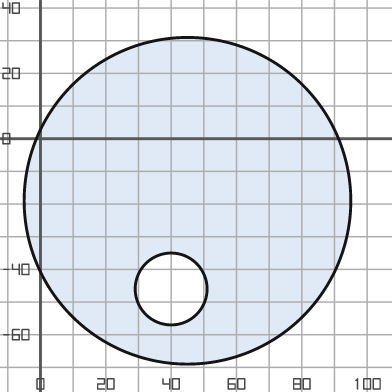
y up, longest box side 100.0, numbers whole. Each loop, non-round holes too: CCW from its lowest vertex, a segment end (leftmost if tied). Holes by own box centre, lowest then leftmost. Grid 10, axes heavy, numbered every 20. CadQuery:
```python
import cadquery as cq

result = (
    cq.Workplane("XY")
    .moveTo(45.0, -19.0)
    .circle(50.0)
    .moveTo(40.0, -46.0)
    .circle(11.0)
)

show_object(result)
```